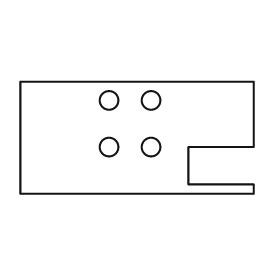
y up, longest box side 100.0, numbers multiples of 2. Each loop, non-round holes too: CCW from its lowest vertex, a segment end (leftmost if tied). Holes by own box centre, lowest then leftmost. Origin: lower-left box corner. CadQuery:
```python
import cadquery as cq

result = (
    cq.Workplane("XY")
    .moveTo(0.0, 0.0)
    .lineTo(100.0, 0.0)
    .lineTo(100.0, 4.0)
    .lineTo(72.0, 4.0)
    .lineTo(72.0, 20.0)
    .lineTo(100.0, 20.0)
    .lineTo(100.0, 48.0)
    .lineTo(0.0, 48.0)
    .close()
    .moveTo(38.0, 20.0)
    .circle(4.0)
    .moveTo(56.0, 20.0)
    .circle(4.0)
    .moveTo(38.0, 40.0)
    .circle(4.0)
    .moveTo(56.0, 40.0)
    .circle(4.0)
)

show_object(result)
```